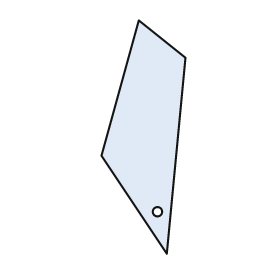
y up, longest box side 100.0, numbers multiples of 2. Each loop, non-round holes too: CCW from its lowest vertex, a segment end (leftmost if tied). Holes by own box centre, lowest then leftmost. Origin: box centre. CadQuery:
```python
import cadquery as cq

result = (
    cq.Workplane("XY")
    .moveTo(10.0, -50.0)
    .lineTo(18.0, 34.0)
    .lineTo(-2.0, 50.0)
    .lineTo(-18.0, -8.0)
    .close()
    .moveTo(6.0, -32.0)
    .circle(2.0)
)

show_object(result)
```